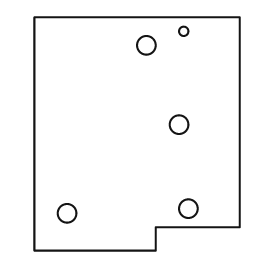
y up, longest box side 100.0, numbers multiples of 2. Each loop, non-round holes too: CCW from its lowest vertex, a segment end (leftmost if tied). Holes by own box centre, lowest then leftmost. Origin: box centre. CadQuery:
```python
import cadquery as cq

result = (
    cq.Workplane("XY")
    .moveTo(-44.0, -50.0)
    .lineTo(8.0, -50.0)
    .lineTo(8.0, -40.0)
    .lineTo(44.0, -40.0)
    .lineTo(44.0, 50.0)
    .lineTo(-44.0, 50.0)
    .close()
    .moveTo(-30.0, -34.0)
    .circle(4.0)
    .moveTo(22.0, -32.0)
    .circle(4.0)
    .moveTo(18.0, 4.0)
    .circle(4.0)
    .moveTo(4.0, 38.0)
    .circle(4.0)
    .moveTo(20.0, 44.0)
    .circle(2.0)
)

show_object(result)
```